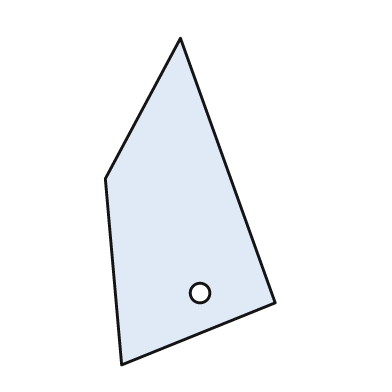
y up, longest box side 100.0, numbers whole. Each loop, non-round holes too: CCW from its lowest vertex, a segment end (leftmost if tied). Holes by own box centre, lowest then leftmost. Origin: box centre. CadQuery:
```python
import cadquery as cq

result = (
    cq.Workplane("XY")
    .moveTo(-21.0, -50.0)
    .lineTo(26.0, -31.0)
    .lineTo(-3.0, 50.0)
    .lineTo(-26.0, 7.0)
    .close()
    .moveTo(3.0, -28.0)
    .circle(3.0)
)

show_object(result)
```